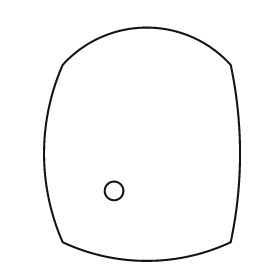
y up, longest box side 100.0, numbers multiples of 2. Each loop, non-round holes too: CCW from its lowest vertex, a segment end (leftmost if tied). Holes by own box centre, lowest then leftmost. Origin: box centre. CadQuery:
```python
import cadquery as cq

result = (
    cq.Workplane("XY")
    .moveTo(-34.0, -42.0)
    .threePointArc((2.0, -50.0), (38.0, -42.0))
    .threePointArc((42.0, -4.0), (38.0, 34.0))
    .threePointArc((2.0, 50.0), (-34.0, 34.0))
    .threePointArc((-42.0, -4.0), (-34.0, -42.0))
    .close()
    .moveTo(-12.0, -20.0)
    .circle(4.0)
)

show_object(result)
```